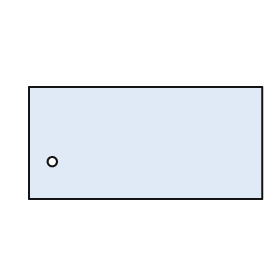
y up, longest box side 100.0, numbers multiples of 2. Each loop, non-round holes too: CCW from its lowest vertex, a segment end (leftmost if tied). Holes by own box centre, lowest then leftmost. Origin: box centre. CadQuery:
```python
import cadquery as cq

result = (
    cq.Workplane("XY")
    .moveTo(-50.0, -24.0)
    .lineTo(50.0, -24.0)
    .lineTo(50.0, 24.0)
    .lineTo(-50.0, 24.0)
    .close()
    .moveTo(-40.0, -8.0)
    .circle(2.0)
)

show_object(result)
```